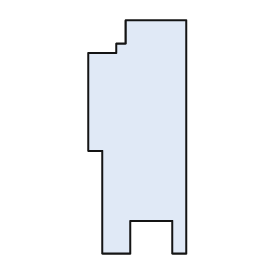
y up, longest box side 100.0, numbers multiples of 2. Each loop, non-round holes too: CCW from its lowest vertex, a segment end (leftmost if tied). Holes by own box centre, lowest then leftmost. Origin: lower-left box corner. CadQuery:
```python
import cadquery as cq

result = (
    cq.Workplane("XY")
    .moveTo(6.0, 0.0)
    .lineTo(18.0, 0.0)
    .lineTo(18.0, 14.0)
    .lineTo(36.0, 14.0)
    .lineTo(36.0, 0.0)
    .lineTo(42.0, 0.0)
    .lineTo(42.0, 100.0)
    .lineTo(16.0, 100.0)
    .lineTo(16.0, 90.0)
    .lineTo(12.0, 90.0)
    .lineTo(12.0, 86.0)
    .lineTo(0.0, 86.0)
    .lineTo(0.0, 44.0)
    .lineTo(6.0, 44.0)
    .close()
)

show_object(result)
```